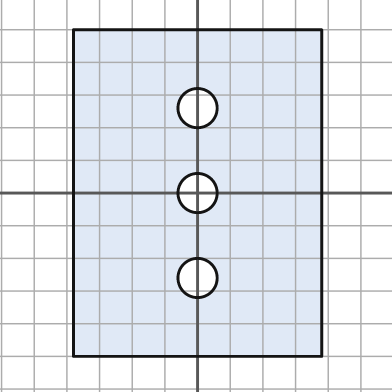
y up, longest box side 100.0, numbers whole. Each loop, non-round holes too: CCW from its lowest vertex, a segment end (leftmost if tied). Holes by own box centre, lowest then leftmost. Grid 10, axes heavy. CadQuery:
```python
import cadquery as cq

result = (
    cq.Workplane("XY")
    .moveTo(-38.0, -50.0)
    .lineTo(38.0, -50.0)
    .lineTo(38.0, 50.0)
    .lineTo(-38.0, 50.0)
    .close()
    .moveTo(0.0, -26.0)
    .circle(6.0)
    .moveTo(0.0, 0.0)
    .circle(6.0)
    .moveTo(0.0, 26.0)
    .circle(6.0)
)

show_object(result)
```